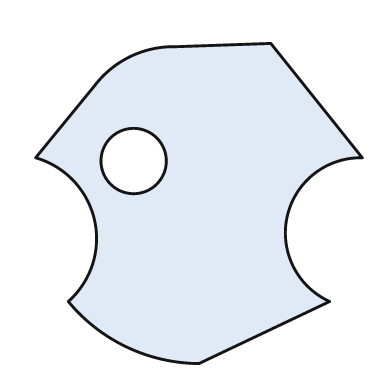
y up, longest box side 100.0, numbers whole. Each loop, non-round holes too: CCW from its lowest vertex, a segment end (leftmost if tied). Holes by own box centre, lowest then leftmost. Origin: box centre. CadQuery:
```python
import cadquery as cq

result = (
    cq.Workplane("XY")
    .moveTo(0.0, -49.0)
    .lineTo(40.0, -30.0)
    .threePointArc((27.0, -4.0), (50.0, 14.0))
    .lineTo(22.0, 49.0)
    .lineTo(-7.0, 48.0)
    .threePointArc((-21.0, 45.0), (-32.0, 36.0))
    .lineTo(-50.0, 14.0)
    .threePointArc((-32.0, -5.0), (-40.0, -30.0))
    .threePointArc((-22.0, -44.0), (0.0, -49.0))
    .close()
    .moveTo(-20.0, 13.0)
    .circle(10.0)
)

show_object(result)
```